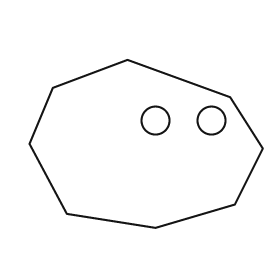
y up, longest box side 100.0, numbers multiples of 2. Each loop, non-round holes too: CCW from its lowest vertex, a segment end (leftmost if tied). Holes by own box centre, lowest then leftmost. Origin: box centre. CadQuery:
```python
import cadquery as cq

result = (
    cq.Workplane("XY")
    .moveTo(4.0, -36.0)
    .lineTo(38.0, -26.0)
    .lineTo(50.0, -2.0)
    .lineTo(36.0, 20.0)
    .lineTo(-8.0, 36.0)
    .lineTo(-40.0, 24.0)
    .lineTo(-50.0, 0.0)
    .lineTo(-34.0, -30.0)
    .close()
    .moveTo(4.0, 10.0)
    .circle(6.0)
    .moveTo(28.0, 10.0)
    .circle(6.0)
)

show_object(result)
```